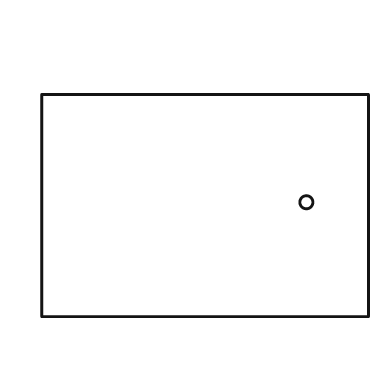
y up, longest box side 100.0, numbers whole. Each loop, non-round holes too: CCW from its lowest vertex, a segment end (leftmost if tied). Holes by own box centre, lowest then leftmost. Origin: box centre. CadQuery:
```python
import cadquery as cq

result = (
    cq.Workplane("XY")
    .moveTo(-50.0, -34.0)
    .lineTo(50.0, -34.0)
    .lineTo(50.0, 34.0)
    .lineTo(-50.0, 34.0)
    .close()
    .moveTo(31.0, 1.0)
    .circle(2.0)
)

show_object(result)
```